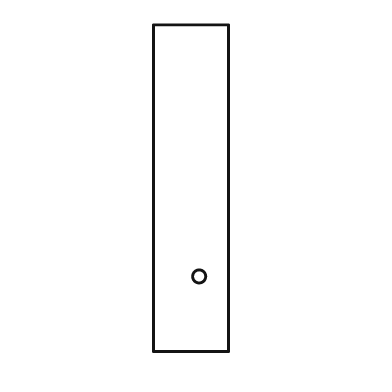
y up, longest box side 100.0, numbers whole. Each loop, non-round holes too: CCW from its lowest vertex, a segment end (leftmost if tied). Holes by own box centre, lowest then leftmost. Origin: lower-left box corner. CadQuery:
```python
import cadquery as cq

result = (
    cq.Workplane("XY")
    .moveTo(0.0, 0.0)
    .lineTo(23.0, 0.0)
    .lineTo(23.0, 100.0)
    .lineTo(0.0, 100.0)
    .close()
    .moveTo(14.0, 23.0)
    .circle(2.0)
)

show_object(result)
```